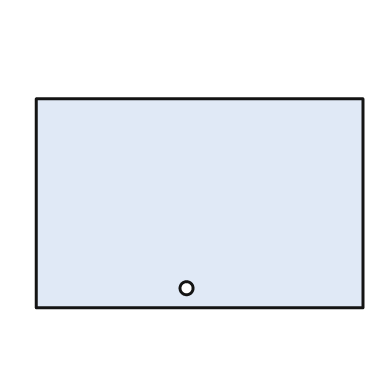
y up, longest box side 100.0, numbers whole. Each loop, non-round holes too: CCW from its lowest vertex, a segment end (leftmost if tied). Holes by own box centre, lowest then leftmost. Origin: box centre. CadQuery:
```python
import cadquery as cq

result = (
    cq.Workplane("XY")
    .moveTo(-50.0, -32.0)
    .lineTo(50.0, -32.0)
    .lineTo(50.0, 32.0)
    .lineTo(-50.0, 32.0)
    .close()
    .moveTo(-4.0, -26.0)
    .circle(2.0)
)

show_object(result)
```